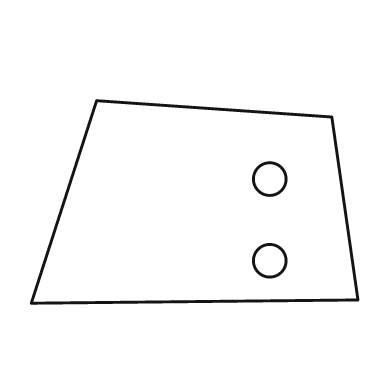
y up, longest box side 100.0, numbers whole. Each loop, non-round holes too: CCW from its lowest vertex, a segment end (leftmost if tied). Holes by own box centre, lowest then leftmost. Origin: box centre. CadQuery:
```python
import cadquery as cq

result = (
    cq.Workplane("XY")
    .moveTo(-50.0, -31.0)
    .lineTo(50.0, -30.0)
    .lineTo(42.0, 26.0)
    .lineTo(-30.0, 31.0)
    .close()
    .moveTo(23.0, -18.0)
    .circle(5.0)
    .moveTo(23.0, 7.0)
    .circle(5.0)
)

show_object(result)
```